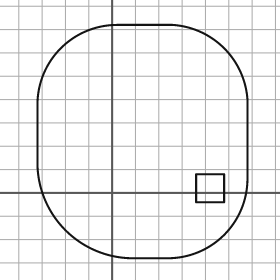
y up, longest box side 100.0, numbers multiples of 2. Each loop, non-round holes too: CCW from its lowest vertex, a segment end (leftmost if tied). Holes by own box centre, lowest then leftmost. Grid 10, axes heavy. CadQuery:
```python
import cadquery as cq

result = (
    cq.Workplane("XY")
    .moveTo(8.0, -28.0)
    .lineTo(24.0, -28.0)
    .threePointArc((48.0, -18.0), (58.0, 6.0))
    .lineTo(58.0, 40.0)
    .threePointArc((48.0, 62.0), (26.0, 72.0))
    .lineTo(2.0, 72.0)
    .threePointArc((-22.0, 62.0), (-32.0, 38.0))
    .lineTo(-32.0, 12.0)
    .threePointArc((-20.0, -16.0), (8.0, -28.0))
    .close()
    .moveTo(36.0, -4.0)
    .lineTo(48.0, -4.0)
    .lineTo(48.0, 8.0)
    .lineTo(36.0, 8.0)
    .close()
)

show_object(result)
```